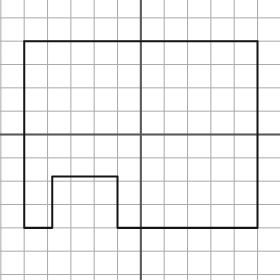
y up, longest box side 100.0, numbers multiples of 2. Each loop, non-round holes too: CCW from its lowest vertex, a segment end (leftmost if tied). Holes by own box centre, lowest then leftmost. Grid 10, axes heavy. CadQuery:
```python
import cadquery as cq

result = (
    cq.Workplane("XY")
    .moveTo(-50.0, -40.0)
    .lineTo(-38.0, -40.0)
    .lineTo(-38.0, -18.0)
    .lineTo(-10.0, -18.0)
    .lineTo(-10.0, -40.0)
    .lineTo(50.0, -40.0)
    .lineTo(50.0, 40.0)
    .lineTo(-50.0, 40.0)
    .close()
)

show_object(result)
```